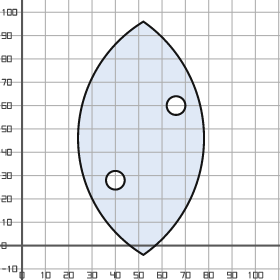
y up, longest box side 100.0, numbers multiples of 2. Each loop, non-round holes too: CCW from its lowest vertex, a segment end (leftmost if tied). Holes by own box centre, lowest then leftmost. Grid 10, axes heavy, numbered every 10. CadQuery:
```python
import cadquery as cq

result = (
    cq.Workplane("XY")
    .moveTo(52.0, -4.0)
    .threePointArc((78.0, 46.0), (52.0, 96.0))
    .threePointArc((24.0, 46.0), (52.0, -4.0))
    .close()
    .moveTo(40.0, 28.0)
    .circle(4.0)
    .moveTo(66.0, 60.0)
    .circle(4.0)
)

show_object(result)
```